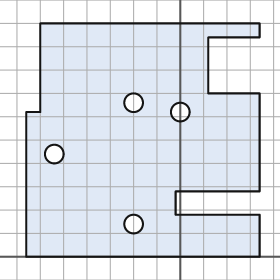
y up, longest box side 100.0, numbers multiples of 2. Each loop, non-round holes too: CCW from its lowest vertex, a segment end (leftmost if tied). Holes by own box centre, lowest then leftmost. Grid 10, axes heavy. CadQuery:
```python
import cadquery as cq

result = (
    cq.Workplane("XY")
    .moveTo(-66.0, 0.0)
    .lineTo(34.0, 0.0)
    .lineTo(34.0, 18.0)
    .lineTo(-2.0, 18.0)
    .lineTo(-2.0, 28.0)
    .lineTo(34.0, 28.0)
    .lineTo(34.0, 70.0)
    .lineTo(12.0, 70.0)
    .lineTo(12.0, 94.0)
    .lineTo(34.0, 94.0)
    .lineTo(34.0, 100.0)
    .lineTo(-60.0, 100.0)
    .lineTo(-60.0, 62.0)
    .lineTo(-66.0, 62.0)
    .close()
    .moveTo(-20.0, 14.0)
    .circle(4.0)
    .moveTo(-54.0, 44.0)
    .circle(4.0)
    .moveTo(0.0, 62.0)
    .circle(4.0)
    .moveTo(-20.0, 66.0)
    .circle(4.0)
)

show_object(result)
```